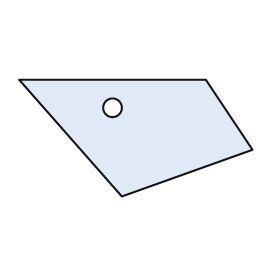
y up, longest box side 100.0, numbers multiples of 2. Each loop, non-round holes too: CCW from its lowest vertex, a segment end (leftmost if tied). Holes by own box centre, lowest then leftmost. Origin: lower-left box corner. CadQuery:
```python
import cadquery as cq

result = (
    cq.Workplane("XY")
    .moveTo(44.0, 0.0)
    .lineTo(100.0, 20.0)
    .lineTo(80.0, 50.0)
    .lineTo(0.0, 50.0)
    .close()
    .moveTo(40.0, 38.0)
    .circle(4.0)
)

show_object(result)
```